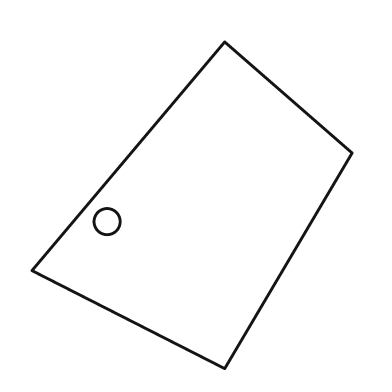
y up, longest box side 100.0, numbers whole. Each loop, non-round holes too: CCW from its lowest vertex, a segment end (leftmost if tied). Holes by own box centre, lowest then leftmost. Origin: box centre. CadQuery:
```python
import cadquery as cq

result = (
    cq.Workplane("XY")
    .moveTo(10.0, -50.0)
    .lineTo(49.0, 16.0)
    .lineTo(10.0, 50.0)
    .lineTo(-49.0, -20.0)
    .close()
    .moveTo(-26.0, -5.0)
    .circle(4.0)
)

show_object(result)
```